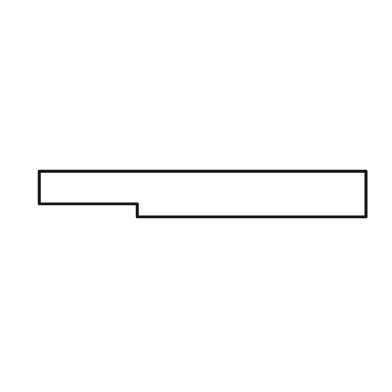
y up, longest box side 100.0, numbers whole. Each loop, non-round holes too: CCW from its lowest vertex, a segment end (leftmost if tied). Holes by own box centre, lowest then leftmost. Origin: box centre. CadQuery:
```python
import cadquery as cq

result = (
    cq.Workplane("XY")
    .moveTo(-20.0, -7.0)
    .lineTo(50.0, -7.0)
    .lineTo(50.0, 7.0)
    .lineTo(-50.0, 7.0)
    .lineTo(-50.0, -3.0)
    .lineTo(-20.0, -3.0)
    .close()
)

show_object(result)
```